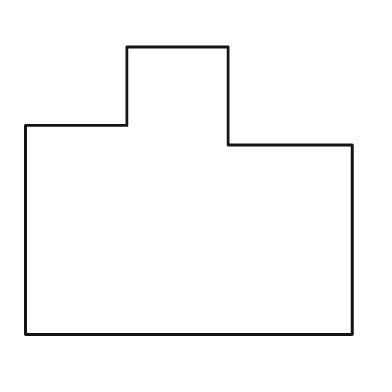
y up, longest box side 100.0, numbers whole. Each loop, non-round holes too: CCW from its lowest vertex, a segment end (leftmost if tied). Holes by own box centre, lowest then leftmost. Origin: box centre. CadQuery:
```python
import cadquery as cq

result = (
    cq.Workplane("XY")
    .moveTo(-50.0, -44.0)
    .lineTo(50.0, -44.0)
    .lineTo(50.0, 14.0)
    .lineTo(12.0, 14.0)
    .lineTo(12.0, 44.0)
    .lineTo(-19.0, 44.0)
    .lineTo(-19.0, 20.0)
    .lineTo(-50.0, 20.0)
    .close()
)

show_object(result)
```